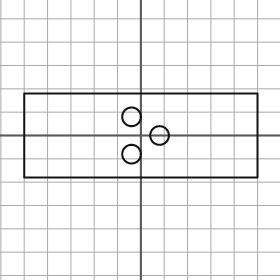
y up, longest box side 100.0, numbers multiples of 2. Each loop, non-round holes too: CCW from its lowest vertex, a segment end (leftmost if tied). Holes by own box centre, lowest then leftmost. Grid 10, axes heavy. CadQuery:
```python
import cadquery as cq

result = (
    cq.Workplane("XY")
    .moveTo(-50.0, -18.0)
    .lineTo(50.0, -18.0)
    .lineTo(50.0, 18.0)
    .lineTo(-50.0, 18.0)
    .close()
    .moveTo(-4.0, -8.0)
    .circle(4.0)
    .moveTo(8.0, 0.0)
    .circle(4.0)
    .moveTo(-4.0, 8.0)
    .circle(4.0)
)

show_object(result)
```